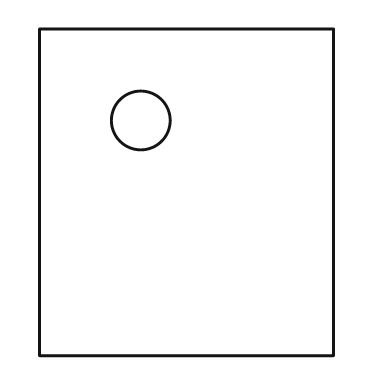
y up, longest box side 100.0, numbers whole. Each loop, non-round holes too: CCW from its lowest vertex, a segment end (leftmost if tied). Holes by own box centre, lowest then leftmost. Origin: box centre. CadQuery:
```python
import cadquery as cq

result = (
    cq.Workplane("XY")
    .moveTo(-45.0, -50.0)
    .lineTo(45.0, -50.0)
    .lineTo(45.0, 50.0)
    .lineTo(-45.0, 50.0)
    .close()
    .moveTo(-14.0, 22.0)
    .circle(9.0)
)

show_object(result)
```